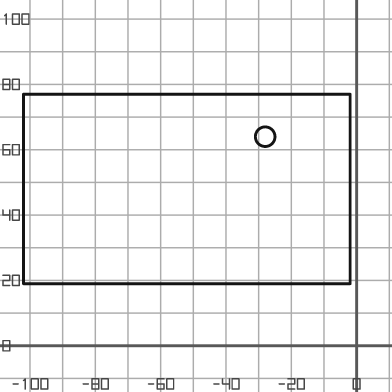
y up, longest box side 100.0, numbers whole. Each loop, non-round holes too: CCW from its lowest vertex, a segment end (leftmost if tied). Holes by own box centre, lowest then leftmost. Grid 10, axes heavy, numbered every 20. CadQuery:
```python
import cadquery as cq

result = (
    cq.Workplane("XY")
    .moveTo(-102.0, 19.0)
    .lineTo(-2.0, 19.0)
    .lineTo(-2.0, 77.0)
    .lineTo(-102.0, 77.0)
    .close()
    .moveTo(-28.0, 64.0)
    .circle(3.0)
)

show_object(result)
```